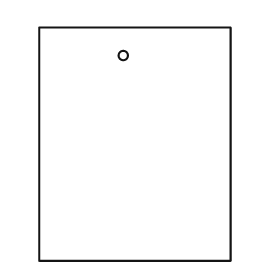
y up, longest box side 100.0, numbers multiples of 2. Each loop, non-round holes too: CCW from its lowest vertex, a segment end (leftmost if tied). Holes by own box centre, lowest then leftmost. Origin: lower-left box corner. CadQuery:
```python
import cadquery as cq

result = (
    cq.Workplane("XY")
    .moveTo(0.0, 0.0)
    .lineTo(82.0, 0.0)
    .lineTo(82.0, 100.0)
    .lineTo(0.0, 100.0)
    .close()
    .moveTo(36.0, 88.0)
    .circle(2.0)
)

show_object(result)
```